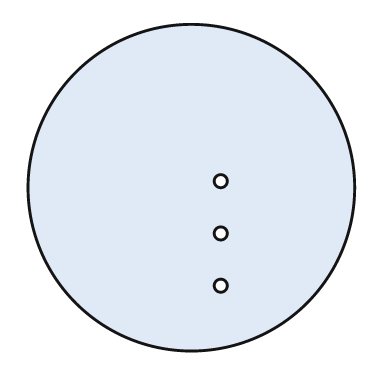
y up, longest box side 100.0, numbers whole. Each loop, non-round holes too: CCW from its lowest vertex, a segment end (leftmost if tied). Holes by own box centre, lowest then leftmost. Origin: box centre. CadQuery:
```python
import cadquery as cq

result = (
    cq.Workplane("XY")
    .moveTo(0.0, 0.0)
    .circle(50.0)
    .moveTo(9.0, -30.0)
    .circle(2.0)
    .moveTo(9.0, -14.0)
    .circle(2.0)
    .moveTo(9.0, 2.0)
    .circle(2.0)
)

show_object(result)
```